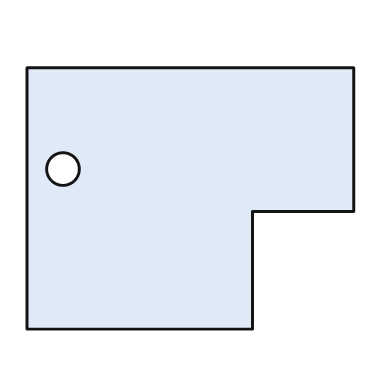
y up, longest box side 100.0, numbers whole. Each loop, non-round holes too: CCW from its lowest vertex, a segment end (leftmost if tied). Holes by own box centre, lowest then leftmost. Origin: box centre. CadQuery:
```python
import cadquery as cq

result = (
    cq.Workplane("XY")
    .moveTo(-50.0, -40.0)
    .lineTo(19.0, -40.0)
    .lineTo(19.0, -4.0)
    .lineTo(50.0, -4.0)
    .lineTo(50.0, 40.0)
    .lineTo(-50.0, 40.0)
    .close()
    .moveTo(-39.0, 9.0)
    .circle(5.0)
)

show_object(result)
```